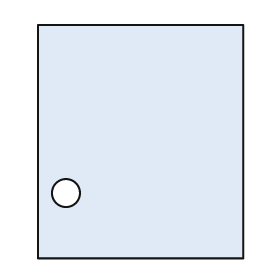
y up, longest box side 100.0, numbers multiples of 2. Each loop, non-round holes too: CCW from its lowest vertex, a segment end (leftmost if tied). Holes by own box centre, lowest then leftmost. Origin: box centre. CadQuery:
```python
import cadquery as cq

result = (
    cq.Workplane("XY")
    .moveTo(-44.0, -50.0)
    .lineTo(44.0, -50.0)
    .lineTo(44.0, 50.0)
    .lineTo(-44.0, 50.0)
    .close()
    .moveTo(-32.0, -22.0)
    .circle(6.0)
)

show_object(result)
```